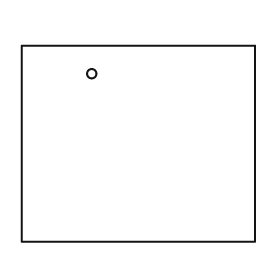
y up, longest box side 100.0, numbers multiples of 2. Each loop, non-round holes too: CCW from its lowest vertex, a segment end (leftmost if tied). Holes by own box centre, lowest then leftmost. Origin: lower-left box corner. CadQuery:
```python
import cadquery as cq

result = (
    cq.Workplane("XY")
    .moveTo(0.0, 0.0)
    .lineTo(100.0, 0.0)
    .lineTo(100.0, 84.0)
    .lineTo(0.0, 84.0)
    .close()
    .moveTo(30.0, 72.0)
    .circle(2.0)
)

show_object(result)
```